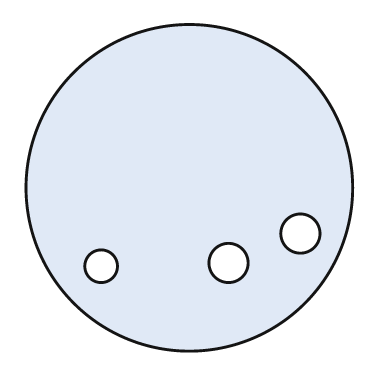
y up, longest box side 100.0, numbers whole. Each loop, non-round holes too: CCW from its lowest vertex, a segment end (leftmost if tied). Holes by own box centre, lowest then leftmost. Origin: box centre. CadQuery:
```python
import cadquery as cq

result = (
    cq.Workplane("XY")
    .moveTo(0.0, 0.0)
    .circle(50.0)
    .moveTo(-27.0, -24.0)
    .circle(5.0)
    .moveTo(12.0, -23.0)
    .circle(6.0)
    .moveTo(34.0, -14.0)
    .circle(6.0)
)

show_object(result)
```